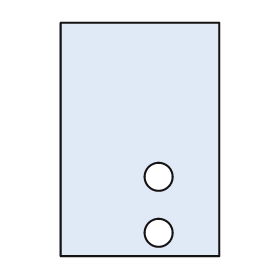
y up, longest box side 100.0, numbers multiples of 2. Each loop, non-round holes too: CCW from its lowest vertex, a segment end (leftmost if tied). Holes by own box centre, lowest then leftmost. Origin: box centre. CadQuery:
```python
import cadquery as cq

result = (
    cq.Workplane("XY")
    .moveTo(-34.0, -50.0)
    .lineTo(34.0, -50.0)
    .lineTo(34.0, 50.0)
    .lineTo(-34.0, 50.0)
    .close()
    .moveTo(8.0, -40.0)
    .circle(6.0)
    .moveTo(8.0, -16.0)
    .circle(6.0)
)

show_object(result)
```